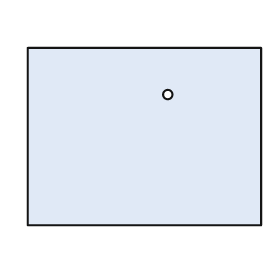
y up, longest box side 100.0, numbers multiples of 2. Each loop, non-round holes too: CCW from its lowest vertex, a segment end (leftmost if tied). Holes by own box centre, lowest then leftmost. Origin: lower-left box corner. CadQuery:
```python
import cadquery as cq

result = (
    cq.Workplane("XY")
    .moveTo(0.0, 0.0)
    .lineTo(100.0, 0.0)
    .lineTo(100.0, 76.0)
    .lineTo(0.0, 76.0)
    .close()
    .moveTo(60.0, 56.0)
    .circle(2.0)
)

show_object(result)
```